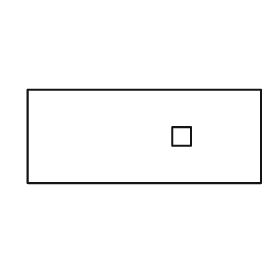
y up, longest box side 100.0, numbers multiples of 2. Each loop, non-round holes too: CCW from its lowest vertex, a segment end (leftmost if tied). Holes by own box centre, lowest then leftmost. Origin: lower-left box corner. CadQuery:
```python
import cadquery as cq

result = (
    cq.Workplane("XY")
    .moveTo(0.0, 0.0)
    .lineTo(100.0, 0.0)
    .lineTo(100.0, 40.0)
    .lineTo(0.0, 40.0)
    .close()
    .moveTo(62.0, 16.0)
    .lineTo(70.0, 16.0)
    .lineTo(70.0, 24.0)
    .lineTo(62.0, 24.0)
    .close()
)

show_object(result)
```